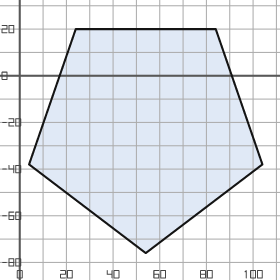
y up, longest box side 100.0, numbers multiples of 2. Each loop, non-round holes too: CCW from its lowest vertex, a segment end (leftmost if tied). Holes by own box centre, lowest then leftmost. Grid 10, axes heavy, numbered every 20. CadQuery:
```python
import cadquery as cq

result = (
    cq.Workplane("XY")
    .moveTo(54.0, -76.0)
    .lineTo(104.0, -38.0)
    .lineTo(84.0, 20.0)
    .lineTo(24.0, 20.0)
    .lineTo(4.0, -38.0)
    .close()
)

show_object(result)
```